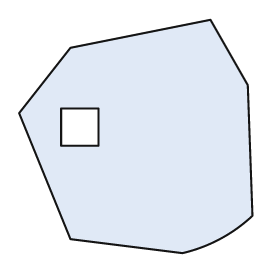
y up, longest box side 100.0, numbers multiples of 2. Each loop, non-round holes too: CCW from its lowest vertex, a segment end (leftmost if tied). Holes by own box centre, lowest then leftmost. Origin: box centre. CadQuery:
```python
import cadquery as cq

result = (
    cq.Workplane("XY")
    .moveTo(20.0, -50.0)
    .threePointArc((36.0, -44.0), (50.0, -34.0))
    .lineTo(48.0, 22.0)
    .lineTo(32.0, 50.0)
    .lineTo(-28.0, 38.0)
    .lineTo(-50.0, 10.0)
    .lineTo(-28.0, -44.0)
    .close()
    .moveTo(-32.0, -4.0)
    .lineTo(-16.0, -4.0)
    .lineTo(-16.0, 12.0)
    .lineTo(-32.0, 12.0)
    .close()
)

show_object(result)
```